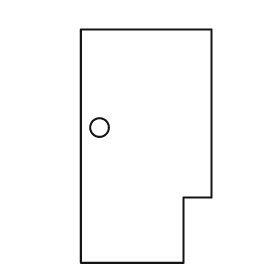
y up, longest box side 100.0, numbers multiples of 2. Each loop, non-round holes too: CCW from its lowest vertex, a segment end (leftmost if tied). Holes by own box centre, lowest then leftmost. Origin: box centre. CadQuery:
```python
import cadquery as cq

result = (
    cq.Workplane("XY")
    .moveTo(-28.0, -50.0)
    .lineTo(16.0, -50.0)
    .lineTo(16.0, -22.0)
    .lineTo(28.0, -22.0)
    .lineTo(28.0, 50.0)
    .lineTo(-28.0, 50.0)
    .close()
    .moveTo(-20.0, 8.0)
    .circle(4.0)
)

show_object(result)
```